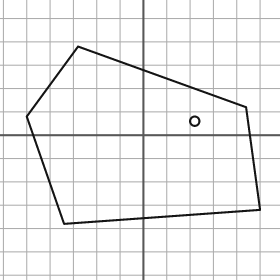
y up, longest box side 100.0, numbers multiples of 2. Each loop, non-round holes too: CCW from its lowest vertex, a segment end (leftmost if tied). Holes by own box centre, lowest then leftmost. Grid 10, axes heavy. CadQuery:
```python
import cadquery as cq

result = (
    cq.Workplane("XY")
    .moveTo(-34.0, -38.0)
    .lineTo(50.0, -32.0)
    .lineTo(44.0, 12.0)
    .lineTo(-28.0, 38.0)
    .lineTo(-50.0, 8.0)
    .close()
    .moveTo(22.0, 6.0)
    .circle(2.0)
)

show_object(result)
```